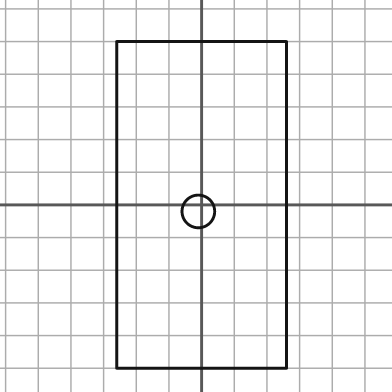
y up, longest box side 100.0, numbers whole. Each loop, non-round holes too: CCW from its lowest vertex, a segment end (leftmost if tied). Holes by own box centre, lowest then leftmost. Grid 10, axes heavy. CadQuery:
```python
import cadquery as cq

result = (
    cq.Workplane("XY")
    .moveTo(-26.0, -50.0)
    .lineTo(26.0, -50.0)
    .lineTo(26.0, 50.0)
    .lineTo(-26.0, 50.0)
    .close()
    .moveTo(-1.0, -2.0)
    .circle(5.0)
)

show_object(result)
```